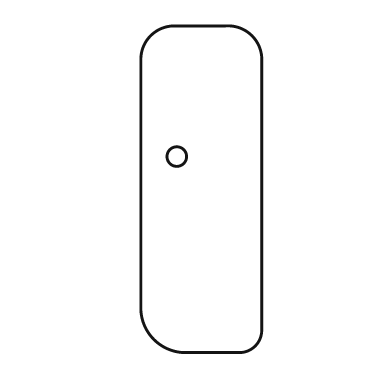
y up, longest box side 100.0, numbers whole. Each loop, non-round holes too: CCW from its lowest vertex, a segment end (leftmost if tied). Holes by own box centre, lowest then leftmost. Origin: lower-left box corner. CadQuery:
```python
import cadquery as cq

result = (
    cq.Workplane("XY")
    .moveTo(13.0, 0.0)
    .lineTo(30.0, 0.0)
    .threePointArc((35.0, 2.0), (37.0, 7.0))
    .lineTo(37.0, 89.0)
    .threePointArc((34.0, 97.0), (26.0, 100.0))
    .lineTo(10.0, 100.0)
    .threePointArc((3.0, 97.0), (0.0, 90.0))
    .lineTo(0.0, 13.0)
    .threePointArc((4.0, 4.0), (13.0, 0.0))
    .close()
    .moveTo(11.0, 60.0)
    .circle(3.0)
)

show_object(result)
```